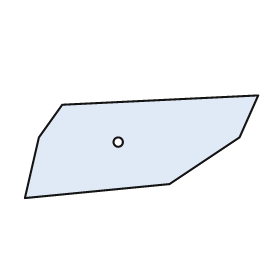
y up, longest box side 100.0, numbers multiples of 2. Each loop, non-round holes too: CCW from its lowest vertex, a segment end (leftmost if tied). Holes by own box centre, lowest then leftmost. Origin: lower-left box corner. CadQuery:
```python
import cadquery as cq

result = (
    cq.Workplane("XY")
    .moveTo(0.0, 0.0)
    .lineTo(62.0, 6.0)
    .lineTo(92.0, 26.0)
    .lineTo(100.0, 44.0)
    .lineTo(16.0, 40.0)
    .lineTo(6.0, 26.0)
    .close()
    .moveTo(40.0, 24.0)
    .circle(2.0)
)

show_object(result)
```